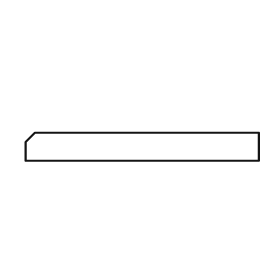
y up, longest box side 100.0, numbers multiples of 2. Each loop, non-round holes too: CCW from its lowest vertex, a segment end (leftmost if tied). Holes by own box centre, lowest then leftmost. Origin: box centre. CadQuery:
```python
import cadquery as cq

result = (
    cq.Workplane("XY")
    .moveTo(-50.0, -6.0)
    .lineTo(50.0, -6.0)
    .lineTo(50.0, 6.0)
    .lineTo(-46.0, 6.0)
    .lineTo(-50.0, 2.0)
    .close()
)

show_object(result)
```